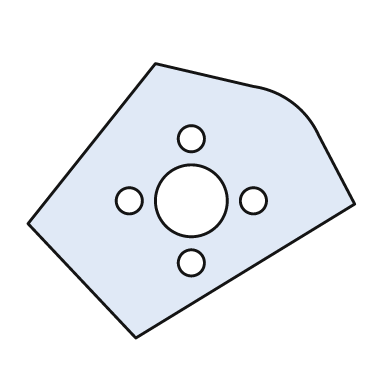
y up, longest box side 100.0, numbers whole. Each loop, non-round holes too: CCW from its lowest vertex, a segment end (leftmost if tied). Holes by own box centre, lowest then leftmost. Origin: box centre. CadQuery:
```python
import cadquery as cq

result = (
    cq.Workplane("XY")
    .moveTo(-17.0, -42.0)
    .lineTo(50.0, -1.0)
    .lineTo(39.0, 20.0)
    .threePointArc((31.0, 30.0), (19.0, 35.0))
    .lineTo(-11.0, 42.0)
    .lineTo(-50.0, -7.0)
    .close()
    .moveTo(0.0, -19.0)
    .circle(4.0)
    .moveTo(-19.0, 0.0)
    .circle(4.0)
    .moveTo(0.0, 0.0)
    .circle(11.0)
    .moveTo(19.0, 0.0)
    .circle(4.0)
    .moveTo(0.0, 19.0)
    .circle(4.0)
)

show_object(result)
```